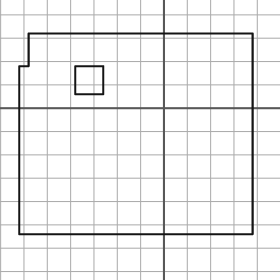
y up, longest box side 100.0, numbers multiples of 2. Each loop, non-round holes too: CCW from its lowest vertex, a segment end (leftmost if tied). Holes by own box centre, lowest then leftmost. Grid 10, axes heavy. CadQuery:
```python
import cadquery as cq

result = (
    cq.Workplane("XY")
    .moveTo(-62.0, -54.0)
    .lineTo(38.0, -54.0)
    .lineTo(38.0, 32.0)
    .lineTo(-58.0, 32.0)
    .lineTo(-58.0, 18.0)
    .lineTo(-62.0, 18.0)
    .close()
    .moveTo(-38.0, 6.0)
    .lineTo(-26.0, 6.0)
    .lineTo(-26.0, 18.0)
    .lineTo(-38.0, 18.0)
    .close()
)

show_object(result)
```